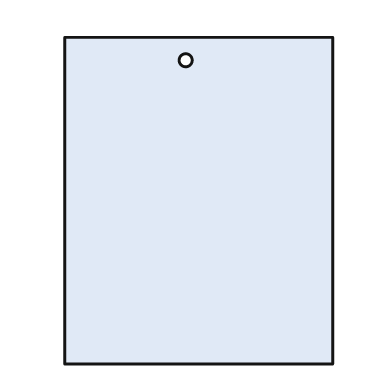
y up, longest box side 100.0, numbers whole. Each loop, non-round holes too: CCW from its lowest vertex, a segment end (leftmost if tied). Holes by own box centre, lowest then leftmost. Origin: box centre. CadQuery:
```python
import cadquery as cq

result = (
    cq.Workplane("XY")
    .moveTo(-41.0, -50.0)
    .lineTo(41.0, -50.0)
    .lineTo(41.0, 50.0)
    .lineTo(-41.0, 50.0)
    .close()
    .moveTo(-4.0, 43.0)
    .circle(2.0)
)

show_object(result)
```